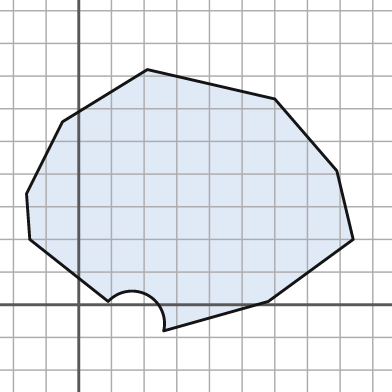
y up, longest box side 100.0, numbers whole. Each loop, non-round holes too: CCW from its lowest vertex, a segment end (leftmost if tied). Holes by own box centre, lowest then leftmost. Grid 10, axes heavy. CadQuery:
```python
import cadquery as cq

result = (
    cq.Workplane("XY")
    .moveTo(26.0, -8.0)
    .lineTo(58.0, 1.0)
    .lineTo(84.0, 20.0)
    .lineTo(79.0, 41.0)
    .lineTo(60.0, 63.0)
    .lineTo(21.0, 72.0)
    .lineTo(-5.0, 56.0)
    .lineTo(-16.0, 34.0)
    .lineTo(-15.0, 20.0)
    .lineTo(9.0, 1.0)
    .threePointArc((21.0, 3.0), (26.0, -8.0))
    .close()
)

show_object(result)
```